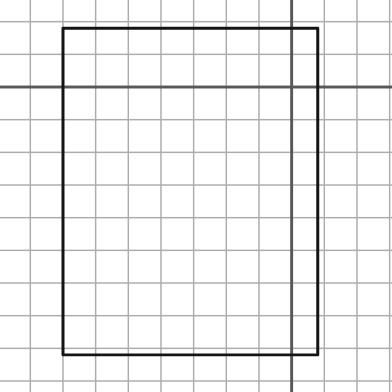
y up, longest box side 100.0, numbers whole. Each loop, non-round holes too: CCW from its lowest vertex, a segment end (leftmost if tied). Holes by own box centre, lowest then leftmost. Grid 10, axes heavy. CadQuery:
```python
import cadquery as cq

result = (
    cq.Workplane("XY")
    .moveTo(-70.0, -82.0)
    .lineTo(8.0, -82.0)
    .lineTo(8.0, 18.0)
    .lineTo(-70.0, 18.0)
    .close()
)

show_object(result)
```